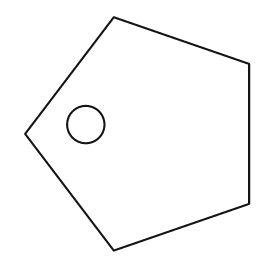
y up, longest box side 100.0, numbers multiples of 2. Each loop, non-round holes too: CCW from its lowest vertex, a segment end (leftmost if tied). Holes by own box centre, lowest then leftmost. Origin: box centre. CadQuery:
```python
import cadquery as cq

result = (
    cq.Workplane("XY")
    .moveTo(-10.0, -50.0)
    .lineTo(48.0, -30.0)
    .lineTo(48.0, 30.0)
    .lineTo(-10.0, 50.0)
    .lineTo(-48.0, 0.0)
    .close()
    .moveTo(-22.0, 4.0)
    .circle(8.0)
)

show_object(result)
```